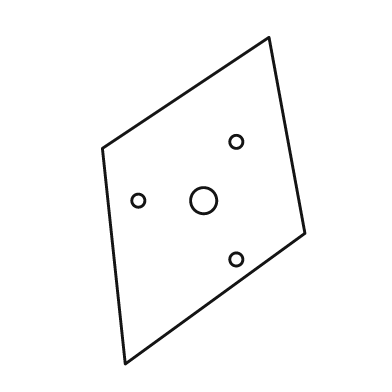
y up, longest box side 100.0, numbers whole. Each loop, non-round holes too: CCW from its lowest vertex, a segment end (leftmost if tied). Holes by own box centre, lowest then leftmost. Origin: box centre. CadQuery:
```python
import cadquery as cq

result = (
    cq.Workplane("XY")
    .moveTo(-24.0, -50.0)
    .lineTo(31.0, -10.0)
    .lineTo(20.0, 50.0)
    .lineTo(-31.0, 16.0)
    .close()
    .moveTo(10.0, -18.0)
    .circle(2.0)
    .moveTo(-20.0, 0.0)
    .circle(2.0)
    .moveTo(0.0, 0.0)
    .circle(4.0)
    .moveTo(10.0, 18.0)
    .circle(2.0)
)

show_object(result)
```